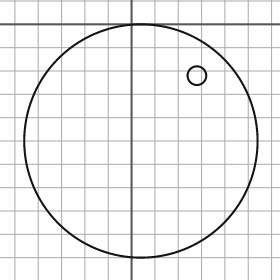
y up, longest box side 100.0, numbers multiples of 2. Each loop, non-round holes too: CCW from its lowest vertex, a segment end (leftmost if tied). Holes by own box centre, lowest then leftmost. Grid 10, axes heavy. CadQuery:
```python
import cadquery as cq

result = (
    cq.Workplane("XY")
    .moveTo(4.0, -50.0)
    .circle(50.0)
    .moveTo(28.0, -22.0)
    .circle(4.0)
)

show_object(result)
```